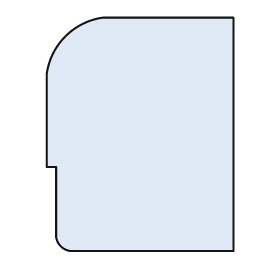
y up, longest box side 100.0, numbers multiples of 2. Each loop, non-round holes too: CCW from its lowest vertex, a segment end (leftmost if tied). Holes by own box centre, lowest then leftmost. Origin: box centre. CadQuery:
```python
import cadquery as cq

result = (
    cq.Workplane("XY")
    .moveTo(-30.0, -50.0)
    .lineTo(40.0, -50.0)
    .lineTo(40.0, 50.0)
    .lineTo(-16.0, 50.0)
    .threePointArc((-32.0, 42.0), (-40.0, 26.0))
    .lineTo(-40.0, -14.0)
    .lineTo(-36.0, -14.0)
    .lineTo(-36.0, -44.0)
    .threePointArc((-34.0, -48.0), (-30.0, -50.0))
    .close()
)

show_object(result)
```